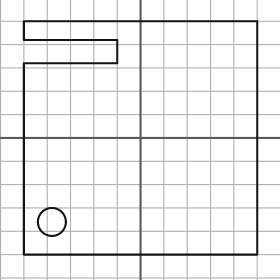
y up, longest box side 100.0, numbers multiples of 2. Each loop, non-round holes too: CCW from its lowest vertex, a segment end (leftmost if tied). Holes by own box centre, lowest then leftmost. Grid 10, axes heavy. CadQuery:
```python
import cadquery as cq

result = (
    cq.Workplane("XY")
    .moveTo(-50.0, -50.0)
    .lineTo(50.0, -50.0)
    .lineTo(50.0, 50.0)
    .lineTo(-50.0, 50.0)
    .lineTo(-50.0, 42.0)
    .lineTo(-10.0, 42.0)
    .lineTo(-10.0, 32.0)
    .lineTo(-50.0, 32.0)
    .close()
    .moveTo(-38.0, -36.0)
    .circle(6.0)
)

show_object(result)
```